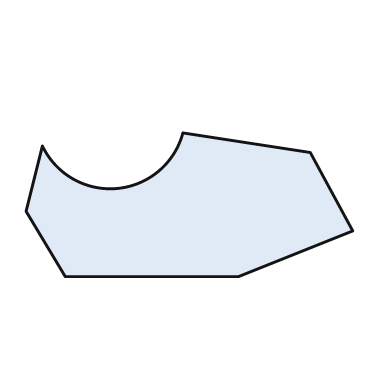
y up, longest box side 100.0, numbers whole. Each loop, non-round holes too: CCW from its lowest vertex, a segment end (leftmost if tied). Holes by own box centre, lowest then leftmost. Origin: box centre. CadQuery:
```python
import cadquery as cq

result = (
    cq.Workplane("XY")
    .moveTo(-38.0, -22.0)
    .lineTo(15.0, -22.0)
    .lineTo(50.0, -8.0)
    .lineTo(37.0, 16.0)
    .lineTo(-2.0, 22.0)
    .threePointArc((-22.0, 5.0), (-45.0, 18.0))
    .lineTo(-50.0, -2.0)
    .close()
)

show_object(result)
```